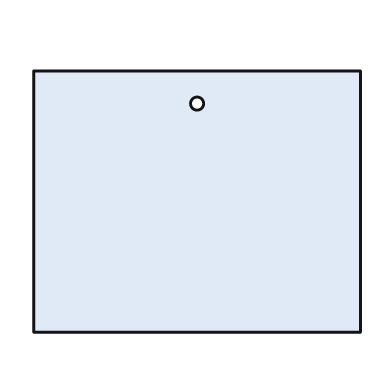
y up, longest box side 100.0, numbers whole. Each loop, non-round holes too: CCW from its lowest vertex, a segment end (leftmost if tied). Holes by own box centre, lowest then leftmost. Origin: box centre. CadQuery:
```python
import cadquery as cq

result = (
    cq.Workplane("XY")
    .moveTo(-50.0, -40.0)
    .lineTo(50.0, -40.0)
    .lineTo(50.0, 40.0)
    .lineTo(-50.0, 40.0)
    .close()
    .moveTo(0.0, 30.0)
    .circle(2.0)
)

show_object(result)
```